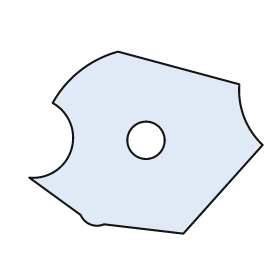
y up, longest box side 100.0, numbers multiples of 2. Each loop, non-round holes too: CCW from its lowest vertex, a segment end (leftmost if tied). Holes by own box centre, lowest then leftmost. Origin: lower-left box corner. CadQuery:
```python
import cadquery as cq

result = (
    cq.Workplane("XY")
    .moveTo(66.0, 0.0)
    .lineTo(100.0, 38.0)
    .threePointArc((92.0, 50.0), (90.0, 64.0))
    .lineTo(38.0, 78.0)
    .threePointArc((22.0, 70.0), (10.0, 56.0))
    .threePointArc((18.0, 36.0), (0.0, 24.0))
    .lineTo(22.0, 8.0)
    .threePointArc((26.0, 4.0), (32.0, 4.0))
    .close()
    .moveTo(50.0, 40.0)
    .circle(8.0)
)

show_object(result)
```